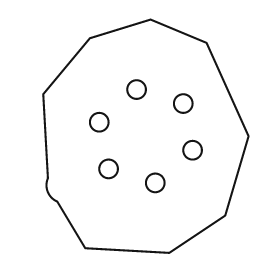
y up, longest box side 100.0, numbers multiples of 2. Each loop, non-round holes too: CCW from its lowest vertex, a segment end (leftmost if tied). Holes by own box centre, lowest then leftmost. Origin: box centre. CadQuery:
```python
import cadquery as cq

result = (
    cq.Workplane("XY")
    .moveTo(10.0, -50.0)
    .lineTo(34.0, -34.0)
    .lineTo(44.0, 0.0)
    .lineTo(26.0, 40.0)
    .lineTo(2.0, 50.0)
    .lineTo(-24.0, 42.0)
    .lineTo(-44.0, 18.0)
    .lineTo(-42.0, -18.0)
    .threePointArc((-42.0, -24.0), (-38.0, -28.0))
    .lineTo(-26.0, -48.0)
    .close()
    .moveTo(4.0, -20.0)
    .circle(4.0)
    .moveTo(-16.0, -14.0)
    .circle(4.0)
    .moveTo(20.0, -6.0)
    .circle(4.0)
    .moveTo(-20.0, 6.0)
    .circle(4.0)
    .moveTo(16.0, 14.0)
    .circle(4.0)
    .moveTo(-4.0, 20.0)
    .circle(4.0)
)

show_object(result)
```